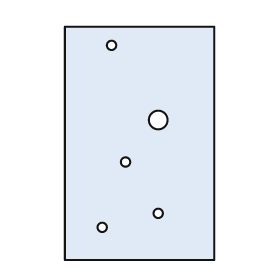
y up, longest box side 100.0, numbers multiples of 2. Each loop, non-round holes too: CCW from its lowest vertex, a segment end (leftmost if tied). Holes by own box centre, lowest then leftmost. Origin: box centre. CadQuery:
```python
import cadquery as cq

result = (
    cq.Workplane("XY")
    .moveTo(-32.0, -50.0)
    .lineTo(32.0, -50.0)
    .lineTo(32.0, 50.0)
    .lineTo(-32.0, 50.0)
    .close()
    .moveTo(-16.0, -36.0)
    .circle(2.0)
    .moveTo(8.0, -30.0)
    .circle(2.0)
    .moveTo(-6.0, -8.0)
    .circle(2.0)
    .moveTo(8.0, 10.0)
    .circle(4.0)
    .moveTo(-12.0, 42.0)
    .circle(2.0)
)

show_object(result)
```